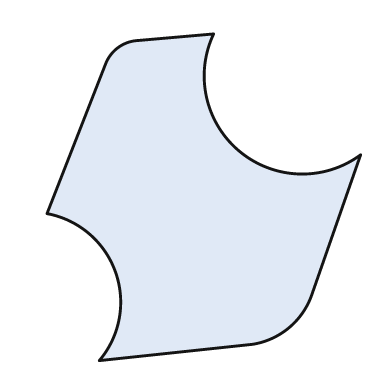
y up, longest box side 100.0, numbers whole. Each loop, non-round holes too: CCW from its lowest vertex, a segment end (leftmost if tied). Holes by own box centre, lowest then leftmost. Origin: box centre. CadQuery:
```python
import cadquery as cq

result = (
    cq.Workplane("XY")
    .moveTo(-32.0, -50.0)
    .lineTo(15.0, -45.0)
    .threePointArc((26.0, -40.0), (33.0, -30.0))
    .lineTo(48.0, 13.0)
    .threePointArc((11.0, 14.0), (3.0, 50.0))
    .lineTo(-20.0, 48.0)
    .threePointArc((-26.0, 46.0), (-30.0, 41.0))
    .lineTo(-48.0, -5.0)
    .threePointArc((-27.0, -23.0), (-32.0, -50.0))
    .close()
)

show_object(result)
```